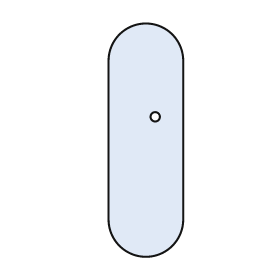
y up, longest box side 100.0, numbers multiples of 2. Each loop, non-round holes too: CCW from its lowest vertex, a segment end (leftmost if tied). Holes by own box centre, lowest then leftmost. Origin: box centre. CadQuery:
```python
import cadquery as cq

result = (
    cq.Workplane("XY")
    .moveTo(-16.0, -34.0)
    .threePointArc((0.0, -50.0), (16.0, -34.0))
    .lineTo(16.0, 34.0)
    .threePointArc((0.0, 50.0), (-16.0, 34.0))
    .close()
    .moveTo(4.0, 10.0)
    .circle(2.0)
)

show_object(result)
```